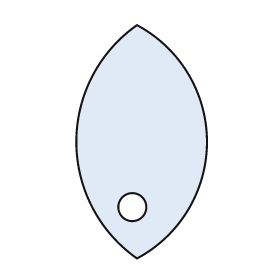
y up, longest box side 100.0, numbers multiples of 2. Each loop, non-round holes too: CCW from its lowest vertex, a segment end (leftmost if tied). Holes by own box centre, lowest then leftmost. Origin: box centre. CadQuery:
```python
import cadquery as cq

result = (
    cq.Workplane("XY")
    .moveTo(-2.0, -50.0)
    .threePointArc((28.0, 0.0), (-2.0, 50.0))
    .threePointArc((-28.0, 0.0), (-2.0, -50.0))
    .close()
    .moveTo(-4.0, -28.0)
    .circle(6.0)
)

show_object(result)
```